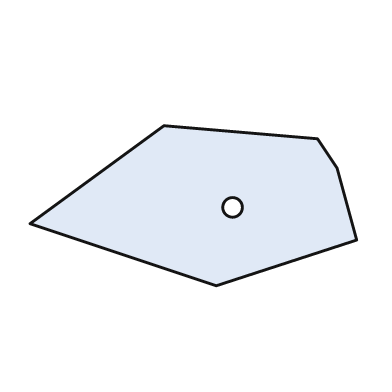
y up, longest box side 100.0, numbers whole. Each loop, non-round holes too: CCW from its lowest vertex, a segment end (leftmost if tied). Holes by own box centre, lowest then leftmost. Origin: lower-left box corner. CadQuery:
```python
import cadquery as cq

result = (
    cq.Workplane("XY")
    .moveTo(57.0, 0.0)
    .lineTo(100.0, 14.0)
    .lineTo(94.0, 36.0)
    .lineTo(88.0, 45.0)
    .lineTo(41.0, 49.0)
    .lineTo(0.0, 19.0)
    .close()
    .moveTo(62.0, 24.0)
    .circle(3.0)
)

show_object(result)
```